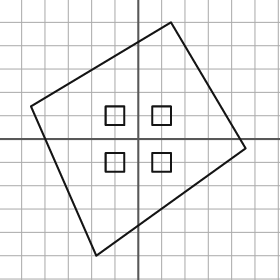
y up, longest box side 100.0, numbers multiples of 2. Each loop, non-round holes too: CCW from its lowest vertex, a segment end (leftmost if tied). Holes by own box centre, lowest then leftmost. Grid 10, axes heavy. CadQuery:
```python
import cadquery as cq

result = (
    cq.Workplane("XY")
    .moveTo(-18.0, -50.0)
    .lineTo(46.0, -4.0)
    .lineTo(14.0, 50.0)
    .lineTo(-46.0, 14.0)
    .close()
    .moveTo(-14.0, -14.0)
    .lineTo(-6.0, -14.0)
    .lineTo(-6.0, -6.0)
    .lineTo(-14.0, -6.0)
    .close()
    .moveTo(6.0, -14.0)
    .lineTo(14.0, -14.0)
    .lineTo(14.0, -6.0)
    .lineTo(6.0, -6.0)
    .close()
    .moveTo(-14.0, 6.0)
    .lineTo(-6.0, 6.0)
    .lineTo(-6.0, 14.0)
    .lineTo(-14.0, 14.0)
    .close()
    .moveTo(6.0, 6.0)
    .lineTo(14.0, 6.0)
    .lineTo(14.0, 14.0)
    .lineTo(6.0, 14.0)
    .close()
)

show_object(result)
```